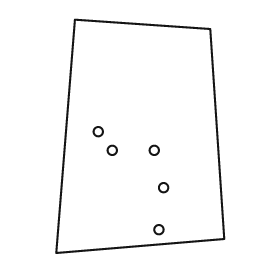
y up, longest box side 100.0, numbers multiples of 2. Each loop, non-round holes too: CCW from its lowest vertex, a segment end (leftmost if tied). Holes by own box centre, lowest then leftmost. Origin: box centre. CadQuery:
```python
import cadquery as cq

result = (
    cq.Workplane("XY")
    .moveTo(-36.0, -50.0)
    .lineTo(36.0, -44.0)
    .lineTo(30.0, 46.0)
    .lineTo(-28.0, 50.0)
    .close()
    .moveTo(8.0, -40.0)
    .circle(2.0)
    .moveTo(10.0, -22.0)
    .circle(2.0)
    .moveTo(-12.0, -6.0)
    .circle(2.0)
    .moveTo(6.0, -6.0)
    .circle(2.0)
    .moveTo(-18.0, 2.0)
    .circle(2.0)
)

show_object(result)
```